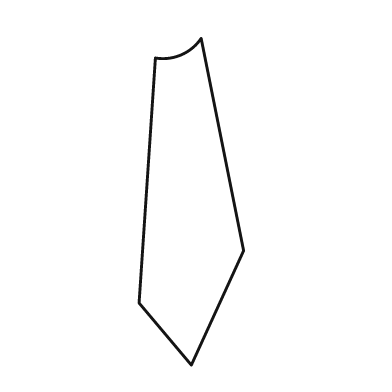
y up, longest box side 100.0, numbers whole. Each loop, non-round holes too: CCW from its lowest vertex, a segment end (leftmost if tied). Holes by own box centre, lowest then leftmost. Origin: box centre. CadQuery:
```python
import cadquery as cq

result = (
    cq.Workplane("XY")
    .moveTo(0.0, -50.0)
    .lineTo(16.0, -15.0)
    .lineTo(3.0, 50.0)
    .threePointArc((-3.0, 45.0), (-11.0, 44.0))
    .lineTo(-16.0, -31.0)
    .close()
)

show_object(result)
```